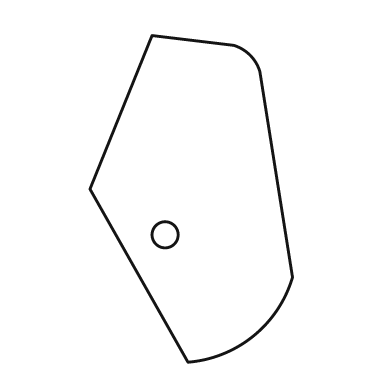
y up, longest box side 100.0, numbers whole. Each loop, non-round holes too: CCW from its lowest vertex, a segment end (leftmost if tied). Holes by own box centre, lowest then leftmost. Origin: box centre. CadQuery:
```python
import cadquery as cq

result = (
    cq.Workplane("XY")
    .moveTo(-1.0, -50.0)
    .threePointArc((19.0, -42.0), (31.0, -24.0))
    .lineTo(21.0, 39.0)
    .threePointArc((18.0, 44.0), (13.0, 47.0))
    .lineTo(-12.0, 50.0)
    .lineTo(-31.0, 3.0)
    .close()
    .moveTo(-8.0, -11.0)
    .circle(4.0)
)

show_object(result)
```